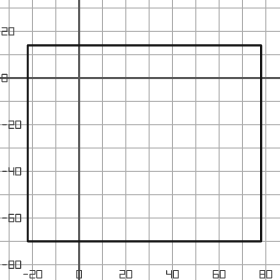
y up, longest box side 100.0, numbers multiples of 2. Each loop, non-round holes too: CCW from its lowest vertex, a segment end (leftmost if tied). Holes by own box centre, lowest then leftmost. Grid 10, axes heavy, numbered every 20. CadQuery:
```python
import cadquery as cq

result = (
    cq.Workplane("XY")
    .moveTo(-22.0, -70.0)
    .lineTo(78.0, -70.0)
    .lineTo(78.0, 14.0)
    .lineTo(-22.0, 14.0)
    .close()
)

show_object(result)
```